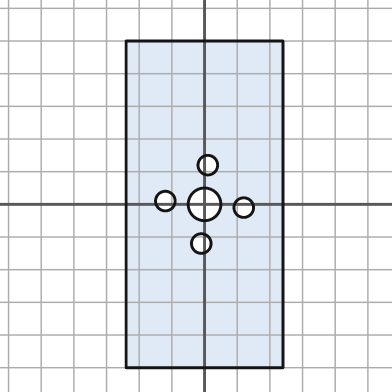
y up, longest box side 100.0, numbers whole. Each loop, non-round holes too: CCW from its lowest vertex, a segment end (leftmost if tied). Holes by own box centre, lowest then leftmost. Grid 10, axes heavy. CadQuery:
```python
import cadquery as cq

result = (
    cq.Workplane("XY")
    .moveTo(-24.0, -50.0)
    .lineTo(24.0, -50.0)
    .lineTo(24.0, 50.0)
    .lineTo(-24.0, 50.0)
    .close()
    .moveTo(-1.0, -12.0)
    .circle(3.0)
    .moveTo(12.0, -1.0)
    .circle(3.0)
    .moveTo(0.0, 0.0)
    .circle(5.0)
    .moveTo(-12.0, 1.0)
    .circle(3.0)
    .moveTo(1.0, 12.0)
    .circle(3.0)
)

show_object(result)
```